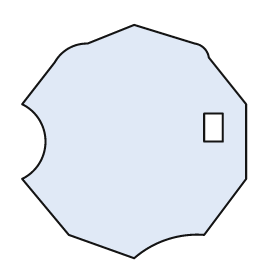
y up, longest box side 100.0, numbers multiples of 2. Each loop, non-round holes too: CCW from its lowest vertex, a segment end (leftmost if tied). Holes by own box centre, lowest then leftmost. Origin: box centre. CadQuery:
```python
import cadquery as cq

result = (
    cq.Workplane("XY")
    .moveTo(0.0, -50.0)
    .threePointArc((14.0, -42.0), (30.0, -40.0))
    .lineTo(48.0, -16.0)
    .lineTo(48.0, 16.0)
    .lineTo(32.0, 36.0)
    .threePointArc((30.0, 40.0), (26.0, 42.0))
    .lineTo(0.0, 50.0)
    .lineTo(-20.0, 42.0)
    .threePointArc((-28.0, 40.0), (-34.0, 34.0))
    .lineTo(-48.0, 16.0)
    .threePointArc((-38.0, 0.0), (-48.0, -16.0))
    .lineTo(-28.0, -40.0)
    .close()
    .moveTo(30.0, 0.0)
    .lineTo(38.0, 0.0)
    .lineTo(38.0, 12.0)
    .lineTo(30.0, 12.0)
    .close()
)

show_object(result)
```